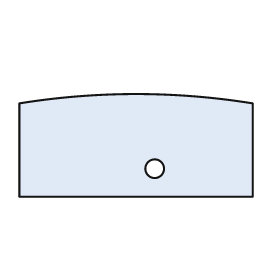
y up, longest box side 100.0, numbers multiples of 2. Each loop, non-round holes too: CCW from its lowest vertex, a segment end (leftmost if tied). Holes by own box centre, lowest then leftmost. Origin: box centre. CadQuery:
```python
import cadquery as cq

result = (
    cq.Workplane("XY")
    .moveTo(-50.0, -22.0)
    .lineTo(50.0, -22.0)
    .lineTo(50.0, 18.0)
    .threePointArc((0.0, 22.0), (-50.0, 18.0))
    .close()
    .moveTo(8.0, -10.0)
    .circle(4.0)
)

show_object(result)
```